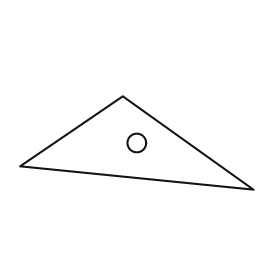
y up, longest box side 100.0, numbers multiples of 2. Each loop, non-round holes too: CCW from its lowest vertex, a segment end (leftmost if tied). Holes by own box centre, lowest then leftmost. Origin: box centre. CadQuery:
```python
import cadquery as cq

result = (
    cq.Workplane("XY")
    .moveTo(50.0, -20.0)
    .lineTo(-6.0, 20.0)
    .lineTo(-50.0, -10.0)
    .close()
    .moveTo(0.0, 0.0)
    .circle(4.0)
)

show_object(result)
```